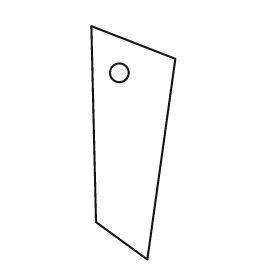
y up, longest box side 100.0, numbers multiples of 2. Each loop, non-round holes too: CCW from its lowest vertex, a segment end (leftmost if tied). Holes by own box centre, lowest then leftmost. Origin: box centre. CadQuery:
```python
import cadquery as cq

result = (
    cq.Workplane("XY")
    .moveTo(6.0, -50.0)
    .lineTo(18.0, 36.0)
    .lineTo(-18.0, 50.0)
    .lineTo(-16.0, -34.0)
    .close()
    .moveTo(-6.0, 30.0)
    .circle(4.0)
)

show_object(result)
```